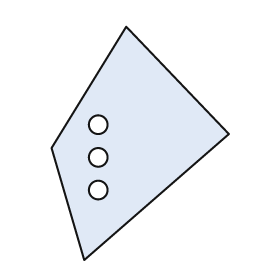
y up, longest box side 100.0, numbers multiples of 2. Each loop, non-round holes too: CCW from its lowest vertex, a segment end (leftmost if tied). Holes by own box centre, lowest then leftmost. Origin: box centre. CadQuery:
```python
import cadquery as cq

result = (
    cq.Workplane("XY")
    .moveTo(-24.0, -50.0)
    .lineTo(38.0, 4.0)
    .lineTo(-6.0, 50.0)
    .lineTo(-38.0, -2.0)
    .close()
    .moveTo(-18.0, -20.0)
    .circle(4.0)
    .moveTo(-18.0, -6.0)
    .circle(4.0)
    .moveTo(-18.0, 8.0)
    .circle(4.0)
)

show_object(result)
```